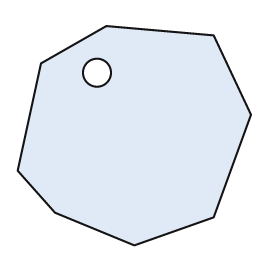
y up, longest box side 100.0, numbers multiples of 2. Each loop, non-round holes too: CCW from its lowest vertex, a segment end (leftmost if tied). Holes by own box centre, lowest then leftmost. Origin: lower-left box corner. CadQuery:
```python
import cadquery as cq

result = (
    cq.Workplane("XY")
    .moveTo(50.0, 0.0)
    .lineTo(84.0, 12.0)
    .lineTo(100.0, 56.0)
    .lineTo(84.0, 90.0)
    .lineTo(38.0, 94.0)
    .lineTo(10.0, 78.0)
    .lineTo(0.0, 32.0)
    .lineTo(16.0, 14.0)
    .close()
    .moveTo(34.0, 74.0)
    .circle(6.0)
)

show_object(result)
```